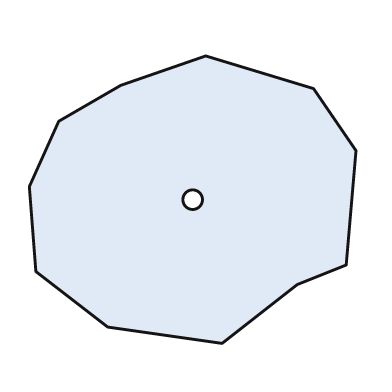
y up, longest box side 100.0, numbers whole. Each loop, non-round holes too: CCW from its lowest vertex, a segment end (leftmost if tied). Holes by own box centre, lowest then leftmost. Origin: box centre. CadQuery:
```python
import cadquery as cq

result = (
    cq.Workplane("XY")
    .moveTo(9.0, -44.0)
    .lineTo(32.0, -26.0)
    .lineTo(47.0, -20.0)
    .lineTo(50.0, 15.0)
    .lineTo(37.0, 34.0)
    .lineTo(4.0, 44.0)
    .lineTo(-22.0, 35.0)
    .lineTo(-41.0, 24.0)
    .lineTo(-50.0, 4.0)
    .lineTo(-48.0, -22.0)
    .lineTo(-26.0, -39.0)
    .close()
    .moveTo(0.0, 0.0)
    .circle(3.0)
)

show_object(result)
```